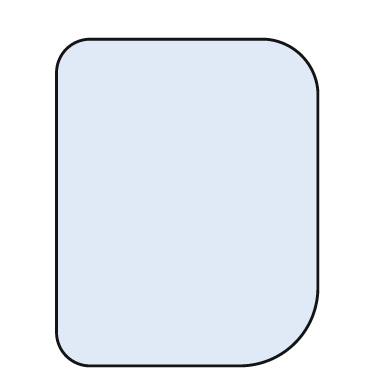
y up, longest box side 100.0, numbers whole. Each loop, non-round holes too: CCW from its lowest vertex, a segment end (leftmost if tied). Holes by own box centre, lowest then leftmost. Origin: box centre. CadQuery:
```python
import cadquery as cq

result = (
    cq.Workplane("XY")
    .moveTo(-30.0, -50.0)
    .lineTo(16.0, -50.0)
    .threePointArc((33.0, -43.0), (40.0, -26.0))
    .lineTo(40.0, 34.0)
    .threePointArc((35.0, 45.0), (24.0, 50.0))
    .lineTo(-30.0, 50.0)
    .threePointArc((-37.0, 47.0), (-40.0, 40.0))
    .lineTo(-40.0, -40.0)
    .threePointArc((-37.0, -47.0), (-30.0, -50.0))
    .close()
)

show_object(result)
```